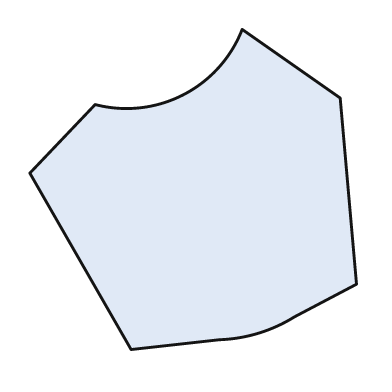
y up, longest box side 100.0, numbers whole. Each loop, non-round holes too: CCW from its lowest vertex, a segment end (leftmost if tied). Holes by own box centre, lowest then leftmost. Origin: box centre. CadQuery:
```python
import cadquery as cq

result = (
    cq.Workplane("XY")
    .moveTo(-19.0, -49.0)
    .lineTo(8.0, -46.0)
    .threePointArc((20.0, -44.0), (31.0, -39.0))
    .lineTo(50.0, -29.0)
    .lineTo(45.0, 28.0)
    .lineTo(15.0, 49.0)
    .threePointArc((-3.0, 29.0), (-30.0, 26.0))
    .lineTo(-50.0, 5.0)
    .close()
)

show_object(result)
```